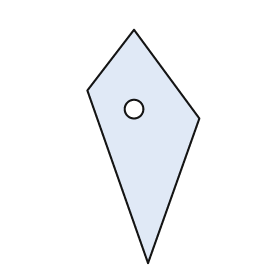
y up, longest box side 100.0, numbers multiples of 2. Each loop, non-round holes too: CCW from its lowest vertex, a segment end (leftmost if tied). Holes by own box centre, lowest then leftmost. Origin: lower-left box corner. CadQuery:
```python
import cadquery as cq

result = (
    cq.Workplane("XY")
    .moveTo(26.0, 0.0)
    .lineTo(48.0, 62.0)
    .lineTo(20.0, 100.0)
    .lineTo(0.0, 74.0)
    .close()
    .moveTo(20.0, 66.0)
    .circle(4.0)
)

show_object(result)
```